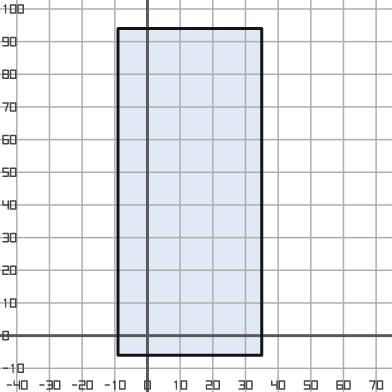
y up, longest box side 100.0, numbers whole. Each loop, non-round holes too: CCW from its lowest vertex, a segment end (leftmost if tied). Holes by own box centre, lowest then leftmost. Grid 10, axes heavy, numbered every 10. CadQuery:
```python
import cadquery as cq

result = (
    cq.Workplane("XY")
    .moveTo(-9.0, -6.0)
    .lineTo(35.0, -6.0)
    .lineTo(35.0, 94.0)
    .lineTo(-9.0, 94.0)
    .close()
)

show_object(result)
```